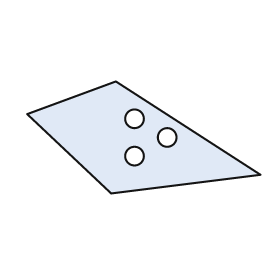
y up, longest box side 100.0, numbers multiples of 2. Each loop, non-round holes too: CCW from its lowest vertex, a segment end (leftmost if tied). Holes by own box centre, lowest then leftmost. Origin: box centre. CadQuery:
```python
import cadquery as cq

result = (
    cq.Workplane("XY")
    .moveTo(-14.0, -24.0)
    .lineTo(50.0, -16.0)
    .lineTo(-12.0, 24.0)
    .lineTo(-50.0, 10.0)
    .close()
    .moveTo(-4.0, -8.0)
    .circle(4.0)
    .moveTo(10.0, 0.0)
    .circle(4.0)
    .moveTo(-4.0, 8.0)
    .circle(4.0)
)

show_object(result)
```